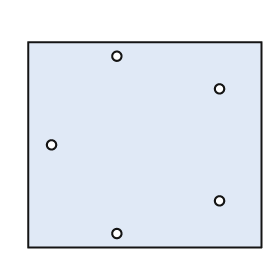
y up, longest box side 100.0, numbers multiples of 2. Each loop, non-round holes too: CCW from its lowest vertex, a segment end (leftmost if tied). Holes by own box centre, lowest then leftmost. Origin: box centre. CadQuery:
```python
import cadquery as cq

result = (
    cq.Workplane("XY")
    .moveTo(-50.0, -44.0)
    .lineTo(50.0, -44.0)
    .lineTo(50.0, 44.0)
    .lineTo(-50.0, 44.0)
    .close()
    .moveTo(-12.0, -38.0)
    .circle(2.0)
    .moveTo(32.0, -24.0)
    .circle(2.0)
    .moveTo(-40.0, 0.0)
    .circle(2.0)
    .moveTo(32.0, 24.0)
    .circle(2.0)
    .moveTo(-12.0, 38.0)
    .circle(2.0)
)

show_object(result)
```